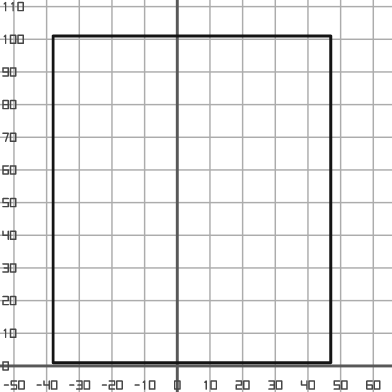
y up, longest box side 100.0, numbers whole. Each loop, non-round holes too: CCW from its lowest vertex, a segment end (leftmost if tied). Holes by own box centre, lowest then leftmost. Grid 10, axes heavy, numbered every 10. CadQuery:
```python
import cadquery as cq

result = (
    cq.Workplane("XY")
    .moveTo(-38.0, 1.0)
    .lineTo(47.0, 1.0)
    .lineTo(47.0, 101.0)
    .lineTo(-38.0, 101.0)
    .close()
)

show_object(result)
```